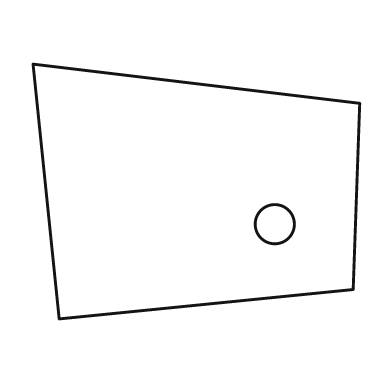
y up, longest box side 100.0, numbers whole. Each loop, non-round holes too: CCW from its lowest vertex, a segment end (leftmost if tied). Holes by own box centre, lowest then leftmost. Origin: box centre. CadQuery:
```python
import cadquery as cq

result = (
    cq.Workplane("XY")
    .moveTo(-42.0, -39.0)
    .lineTo(48.0, -30.0)
    .lineTo(50.0, 27.0)
    .lineTo(-50.0, 39.0)
    .close()
    .moveTo(24.0, -10.0)
    .circle(6.0)
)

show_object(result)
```